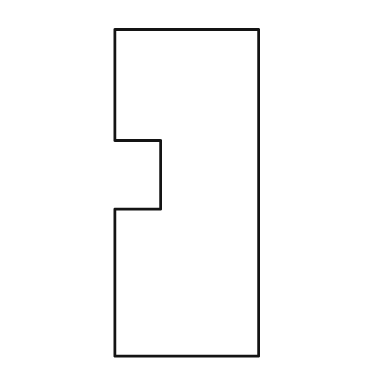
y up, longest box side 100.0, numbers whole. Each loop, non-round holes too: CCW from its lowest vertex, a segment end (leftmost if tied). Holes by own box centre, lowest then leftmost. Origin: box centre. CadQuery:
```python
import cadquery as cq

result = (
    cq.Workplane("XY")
    .moveTo(-22.0, -50.0)
    .lineTo(22.0, -50.0)
    .lineTo(22.0, 50.0)
    .lineTo(-22.0, 50.0)
    .lineTo(-22.0, 16.0)
    .lineTo(-8.0, 16.0)
    .lineTo(-8.0, -5.0)
    .lineTo(-22.0, -5.0)
    .close()
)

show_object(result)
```